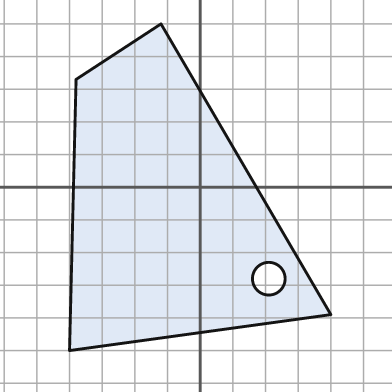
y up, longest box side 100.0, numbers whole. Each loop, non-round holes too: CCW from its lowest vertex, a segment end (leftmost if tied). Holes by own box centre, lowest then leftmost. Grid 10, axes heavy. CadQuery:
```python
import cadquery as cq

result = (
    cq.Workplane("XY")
    .moveTo(-40.0, -50.0)
    .lineTo(40.0, -39.0)
    .lineTo(-12.0, 50.0)
    .lineTo(-38.0, 33.0)
    .close()
    .moveTo(21.0, -28.0)
    .circle(5.0)
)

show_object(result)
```